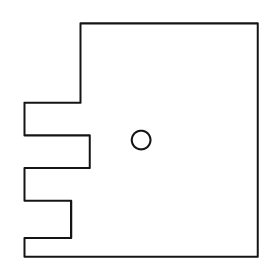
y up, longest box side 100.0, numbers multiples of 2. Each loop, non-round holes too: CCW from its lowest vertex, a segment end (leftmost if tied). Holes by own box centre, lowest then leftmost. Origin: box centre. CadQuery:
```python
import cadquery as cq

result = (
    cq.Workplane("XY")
    .moveTo(-50.0, -50.0)
    .lineTo(50.0, -50.0)
    .lineTo(50.0, 50.0)
    .lineTo(-26.0, 50.0)
    .lineTo(-26.0, 16.0)
    .lineTo(-50.0, 16.0)
    .lineTo(-50.0, 2.0)
    .lineTo(-22.0, 2.0)
    .lineTo(-22.0, -12.0)
    .lineTo(-50.0, -12.0)
    .lineTo(-50.0, -26.0)
    .lineTo(-30.0, -26.0)
    .lineTo(-30.0, -42.0)
    .lineTo(-50.0, -42.0)
    .close()
    .moveTo(0.0, 0.0)
    .circle(4.0)
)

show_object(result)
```